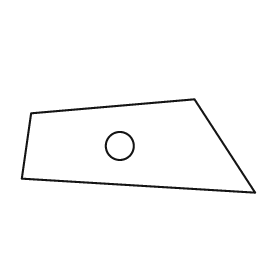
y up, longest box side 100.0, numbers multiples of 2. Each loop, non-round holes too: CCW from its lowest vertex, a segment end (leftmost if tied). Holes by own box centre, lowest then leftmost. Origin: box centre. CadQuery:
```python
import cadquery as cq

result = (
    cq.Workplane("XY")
    .moveTo(50.0, -20.0)
    .lineTo(24.0, 20.0)
    .lineTo(-46.0, 14.0)
    .lineTo(-50.0, -14.0)
    .close()
    .moveTo(-8.0, 0.0)
    .circle(6.0)
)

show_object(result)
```